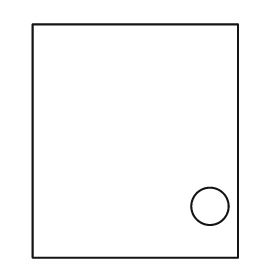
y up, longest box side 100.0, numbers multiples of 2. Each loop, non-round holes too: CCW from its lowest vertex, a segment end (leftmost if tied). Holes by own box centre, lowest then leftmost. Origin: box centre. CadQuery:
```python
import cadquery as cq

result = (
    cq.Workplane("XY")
    .moveTo(-44.0, -50.0)
    .lineTo(44.0, -50.0)
    .lineTo(44.0, 50.0)
    .lineTo(-44.0, 50.0)
    .close()
    .moveTo(32.0, -28.0)
    .circle(8.0)
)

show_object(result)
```